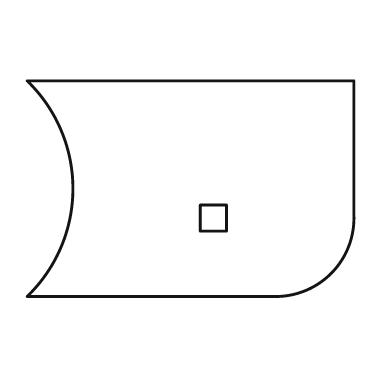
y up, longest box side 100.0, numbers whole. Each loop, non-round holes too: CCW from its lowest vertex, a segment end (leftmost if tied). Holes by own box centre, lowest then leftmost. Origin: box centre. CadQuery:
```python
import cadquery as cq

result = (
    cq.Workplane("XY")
    .moveTo(-50.0, -33.0)
    .lineTo(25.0, -33.0)
    .threePointArc((43.0, -26.0), (50.0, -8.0))
    .lineTo(50.0, 33.0)
    .lineTo(-50.0, 33.0)
    .threePointArc((-36.0, 0.0), (-50.0, -33.0))
    .close()
    .moveTo(3.0, -13.0)
    .lineTo(11.0, -13.0)
    .lineTo(11.0, -5.0)
    .lineTo(3.0, -5.0)
    .close()
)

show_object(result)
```